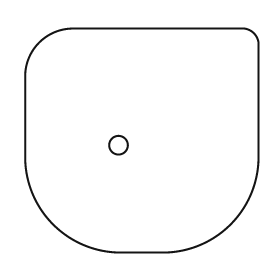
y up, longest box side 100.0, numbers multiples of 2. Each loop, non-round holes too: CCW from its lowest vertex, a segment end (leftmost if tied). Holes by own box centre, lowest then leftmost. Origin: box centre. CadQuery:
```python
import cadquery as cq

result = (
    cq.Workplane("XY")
    .moveTo(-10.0, -48.0)
    .lineTo(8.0, -48.0)
    .threePointArc((38.0, -36.0), (50.0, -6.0))
    .lineTo(50.0, 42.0)
    .threePointArc((48.0, 46.0), (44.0, 48.0))
    .lineTo(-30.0, 48.0)
    .threePointArc((-44.0, 42.0), (-50.0, 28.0))
    .lineTo(-50.0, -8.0)
    .threePointArc((-38.0, -36.0), (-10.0, -48.0))
    .close()
    .moveTo(-10.0, -2.0)
    .circle(4.0)
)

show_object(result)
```